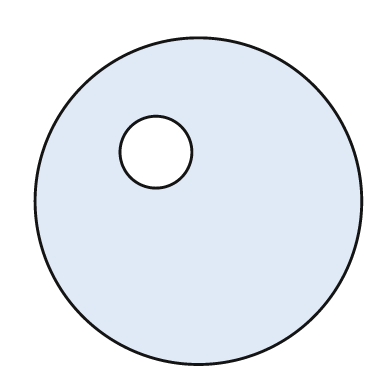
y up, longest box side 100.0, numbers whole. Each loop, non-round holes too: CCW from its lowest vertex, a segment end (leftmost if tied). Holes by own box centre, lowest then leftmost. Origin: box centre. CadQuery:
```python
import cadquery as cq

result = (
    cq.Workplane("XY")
    .moveTo(0.0, 0.0)
    .circle(50.0)
    .moveTo(-13.0, 15.0)
    .circle(11.0)
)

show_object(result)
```